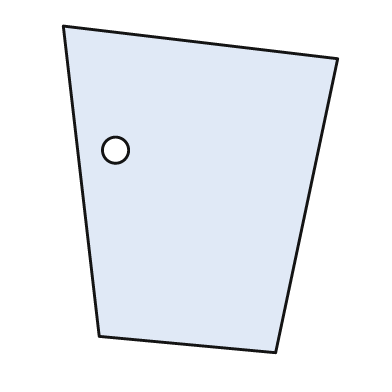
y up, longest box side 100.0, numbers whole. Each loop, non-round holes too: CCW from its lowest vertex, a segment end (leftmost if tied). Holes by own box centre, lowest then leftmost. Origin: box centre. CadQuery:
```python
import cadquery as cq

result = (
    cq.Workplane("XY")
    .moveTo(23.0, -50.0)
    .lineTo(42.0, 40.0)
    .lineTo(-42.0, 50.0)
    .lineTo(-31.0, -45.0)
    .close()
    .moveTo(-26.0, 12.0)
    .circle(4.0)
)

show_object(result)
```